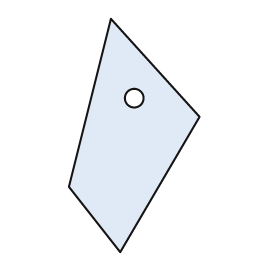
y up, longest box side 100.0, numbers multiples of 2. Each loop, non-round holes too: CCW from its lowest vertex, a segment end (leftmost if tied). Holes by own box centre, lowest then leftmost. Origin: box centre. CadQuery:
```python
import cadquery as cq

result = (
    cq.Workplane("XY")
    .moveTo(-6.0, -50.0)
    .lineTo(28.0, 8.0)
    .lineTo(-10.0, 50.0)
    .lineTo(-28.0, -22.0)
    .close()
    .moveTo(0.0, 16.0)
    .circle(4.0)
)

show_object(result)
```